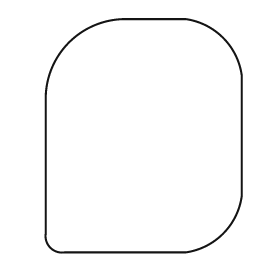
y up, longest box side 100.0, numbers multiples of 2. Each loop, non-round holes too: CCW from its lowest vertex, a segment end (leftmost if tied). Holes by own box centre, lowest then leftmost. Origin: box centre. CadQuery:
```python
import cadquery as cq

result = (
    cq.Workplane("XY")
    .moveTo(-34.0, -50.0)
    .lineTo(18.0, -50.0)
    .threePointArc((34.0, -42.0), (42.0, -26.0))
    .lineTo(42.0, 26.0)
    .threePointArc((34.0, 42.0), (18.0, 50.0))
    .lineTo(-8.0, 50.0)
    .threePointArc((-32.0, 40.0), (-42.0, 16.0))
    .lineTo(-42.0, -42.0)
    .threePointArc((-40.0, -48.0), (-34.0, -50.0))
    .close()
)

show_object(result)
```